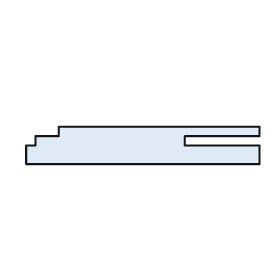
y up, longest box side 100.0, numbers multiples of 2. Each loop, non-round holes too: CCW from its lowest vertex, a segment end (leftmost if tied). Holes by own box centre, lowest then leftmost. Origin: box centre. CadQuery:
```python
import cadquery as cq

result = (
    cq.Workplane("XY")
    .moveTo(-50.0, -8.0)
    .lineTo(50.0, -8.0)
    .lineTo(50.0, 0.0)
    .lineTo(18.0, 0.0)
    .lineTo(18.0, 4.0)
    .lineTo(50.0, 4.0)
    .lineTo(50.0, 8.0)
    .lineTo(-36.0, 8.0)
    .lineTo(-36.0, 4.0)
    .lineTo(-46.0, 4.0)
    .lineTo(-46.0, 0.0)
    .lineTo(-50.0, 0.0)
    .close()
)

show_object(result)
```